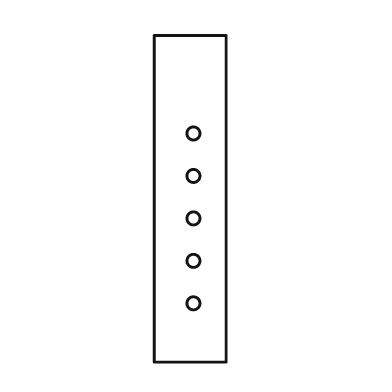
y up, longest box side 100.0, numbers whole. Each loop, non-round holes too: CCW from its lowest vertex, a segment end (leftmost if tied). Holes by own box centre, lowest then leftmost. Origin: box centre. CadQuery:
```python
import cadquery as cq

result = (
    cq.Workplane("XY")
    .moveTo(-11.0, -50.0)
    .lineTo(11.0, -50.0)
    .lineTo(11.0, 50.0)
    .lineTo(-11.0, 50.0)
    .close()
    .moveTo(1.0, -32.0)
    .circle(2.0)
    .moveTo(1.0, -19.0)
    .circle(2.0)
    .moveTo(1.0, -6.0)
    .circle(2.0)
    .moveTo(1.0, 7.0)
    .circle(2.0)
    .moveTo(1.0, 20.0)
    .circle(2.0)
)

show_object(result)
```